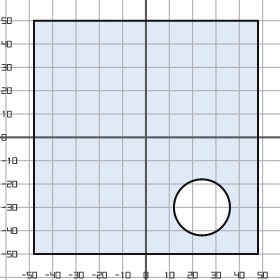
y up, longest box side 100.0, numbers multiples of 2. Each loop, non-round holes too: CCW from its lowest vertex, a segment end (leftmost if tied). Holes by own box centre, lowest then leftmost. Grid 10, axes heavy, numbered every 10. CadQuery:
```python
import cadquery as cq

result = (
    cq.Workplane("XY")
    .moveTo(-48.0, -50.0)
    .lineTo(48.0, -50.0)
    .lineTo(48.0, 50.0)
    .lineTo(-48.0, 50.0)
    .close()
    .moveTo(24.0, -30.0)
    .circle(12.0)
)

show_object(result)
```